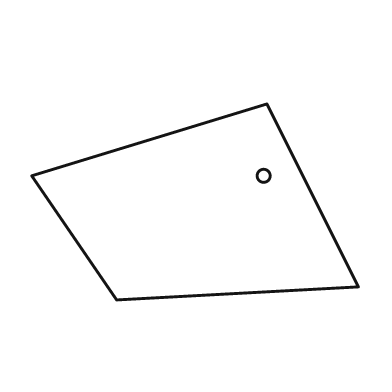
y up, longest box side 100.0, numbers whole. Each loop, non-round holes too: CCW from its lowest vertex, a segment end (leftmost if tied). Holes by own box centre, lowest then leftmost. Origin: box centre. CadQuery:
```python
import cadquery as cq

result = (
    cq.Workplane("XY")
    .moveTo(-24.0, -30.0)
    .lineTo(50.0, -26.0)
    .lineTo(22.0, 30.0)
    .lineTo(-50.0, 8.0)
    .close()
    .moveTo(21.0, 8.0)
    .circle(2.0)
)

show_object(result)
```